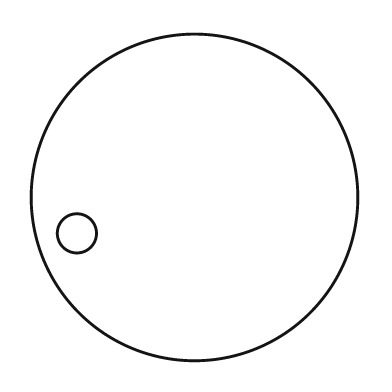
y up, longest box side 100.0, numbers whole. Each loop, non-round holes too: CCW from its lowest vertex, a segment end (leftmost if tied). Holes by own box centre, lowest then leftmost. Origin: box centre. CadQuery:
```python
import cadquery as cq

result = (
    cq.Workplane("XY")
    .moveTo(0.0, 0.0)
    .circle(50.0)
    .moveTo(-36.0, -11.0)
    .circle(6.0)
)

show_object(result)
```